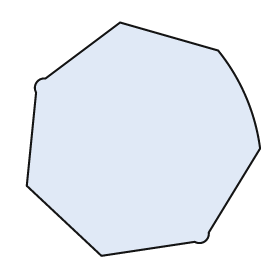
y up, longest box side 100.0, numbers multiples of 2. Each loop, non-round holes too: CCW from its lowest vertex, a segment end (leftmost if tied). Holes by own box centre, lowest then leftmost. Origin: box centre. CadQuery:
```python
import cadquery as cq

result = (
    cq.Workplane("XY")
    .moveTo(-18.0, -50.0)
    .lineTo(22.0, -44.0)
    .threePointArc((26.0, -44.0), (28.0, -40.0))
    .lineTo(50.0, -4.0)
    .threePointArc((44.0, 18.0), (32.0, 38.0))
    .lineTo(-10.0, 50.0)
    .lineTo(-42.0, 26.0)
    .threePointArc((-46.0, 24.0), (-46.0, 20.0))
    .lineTo(-50.0, -20.0)
    .close()
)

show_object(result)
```